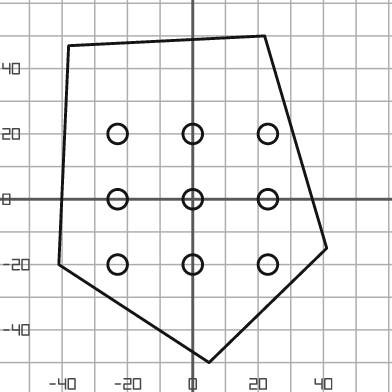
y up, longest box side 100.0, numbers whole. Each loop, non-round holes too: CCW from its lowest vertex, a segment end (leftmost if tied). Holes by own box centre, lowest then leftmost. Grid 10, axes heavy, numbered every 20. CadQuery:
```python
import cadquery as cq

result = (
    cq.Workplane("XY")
    .moveTo(5.0, -50.0)
    .lineTo(41.0, -15.0)
    .lineTo(22.0, 50.0)
    .lineTo(-38.0, 47.0)
    .lineTo(-41.0, -20.0)
    .close()
    .moveTo(-23.0, -20.0)
    .circle(3.0)
    .moveTo(0.0, -20.0)
    .circle(3.0)
    .moveTo(23.0, -20.0)
    .circle(3.0)
    .moveTo(-23.0, 0.0)
    .circle(3.0)
    .moveTo(0.0, 0.0)
    .circle(3.0)
    .moveTo(23.0, 0.0)
    .circle(3.0)
    .moveTo(-23.0, 20.0)
    .circle(3.0)
    .moveTo(0.0, 20.0)
    .circle(3.0)
    .moveTo(23.0, 20.0)
    .circle(3.0)
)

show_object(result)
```